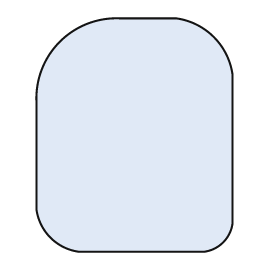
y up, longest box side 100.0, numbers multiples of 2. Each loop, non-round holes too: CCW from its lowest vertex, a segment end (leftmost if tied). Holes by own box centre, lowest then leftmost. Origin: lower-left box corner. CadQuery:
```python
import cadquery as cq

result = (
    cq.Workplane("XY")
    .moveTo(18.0, 0.0)
    .lineTo(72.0, 0.0)
    .threePointArc((80.0, 4.0), (84.0, 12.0))
    .lineTo(84.0, 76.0)
    .threePointArc((76.0, 92.0), (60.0, 100.0))
    .lineTo(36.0, 100.0)
    .threePointArc((10.0, 90.0), (0.0, 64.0))
    .lineTo(0.0, 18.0)
    .threePointArc((6.0, 6.0), (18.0, 0.0))
    .close()
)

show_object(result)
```